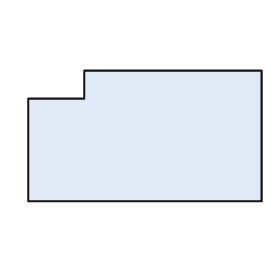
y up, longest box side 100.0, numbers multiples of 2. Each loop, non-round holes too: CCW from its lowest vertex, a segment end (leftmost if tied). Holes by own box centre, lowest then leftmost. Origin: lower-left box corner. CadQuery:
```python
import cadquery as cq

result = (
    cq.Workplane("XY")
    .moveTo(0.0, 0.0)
    .lineTo(100.0, 0.0)
    .lineTo(100.0, 56.0)
    .lineTo(24.0, 56.0)
    .lineTo(24.0, 44.0)
    .lineTo(0.0, 44.0)
    .close()
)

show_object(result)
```